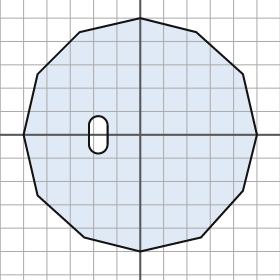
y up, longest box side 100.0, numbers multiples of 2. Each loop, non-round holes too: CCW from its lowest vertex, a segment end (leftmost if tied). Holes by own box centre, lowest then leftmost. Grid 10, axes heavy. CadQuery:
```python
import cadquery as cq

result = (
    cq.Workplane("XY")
    .moveTo(0.0, -50.0)
    .lineTo(26.0, -44.0)
    .lineTo(44.0, -24.0)
    .lineTo(50.0, 0.0)
    .lineTo(44.0, 26.0)
    .lineTo(24.0, 44.0)
    .lineTo(0.0, 50.0)
    .lineTo(-26.0, 44.0)
    .lineTo(-44.0, 26.0)
    .lineTo(-50.0, 0.0)
    .lineTo(-44.0, -26.0)
    .lineTo(-24.0, -44.0)
    .close()
    .moveTo(-22.0, -4.0)
    .threePointArc((-18.0, -8.0), (-14.0, -4.0))
    .lineTo(-14.0, 4.0)
    .threePointArc((-18.0, 8.0), (-22.0, 4.0))
    .close()
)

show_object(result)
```